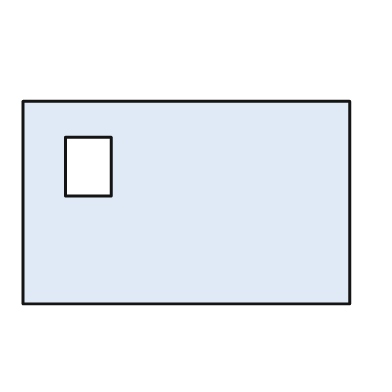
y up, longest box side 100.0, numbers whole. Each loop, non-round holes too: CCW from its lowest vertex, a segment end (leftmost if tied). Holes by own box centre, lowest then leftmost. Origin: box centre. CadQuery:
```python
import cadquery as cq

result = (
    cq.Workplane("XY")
    .moveTo(-50.0, -31.0)
    .lineTo(50.0, -31.0)
    .lineTo(50.0, 31.0)
    .lineTo(-50.0, 31.0)
    .close()
    .moveTo(-37.0, 2.0)
    .lineTo(-23.0, 2.0)
    .lineTo(-23.0, 20.0)
    .lineTo(-37.0, 20.0)
    .close()
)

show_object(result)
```